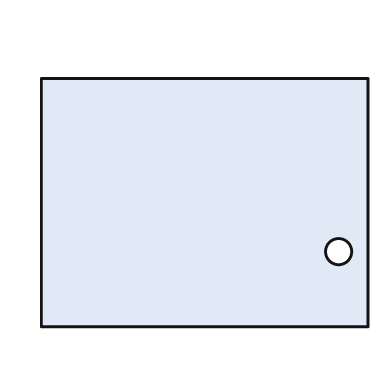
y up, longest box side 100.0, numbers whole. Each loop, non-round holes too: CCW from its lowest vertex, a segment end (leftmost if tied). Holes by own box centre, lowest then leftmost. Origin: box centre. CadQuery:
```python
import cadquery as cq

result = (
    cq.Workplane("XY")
    .moveTo(-50.0, -38.0)
    .lineTo(50.0, -38.0)
    .lineTo(50.0, 38.0)
    .lineTo(-50.0, 38.0)
    .close()
    .moveTo(41.0, -15.0)
    .circle(4.0)
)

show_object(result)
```